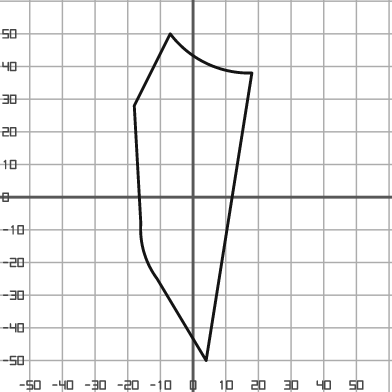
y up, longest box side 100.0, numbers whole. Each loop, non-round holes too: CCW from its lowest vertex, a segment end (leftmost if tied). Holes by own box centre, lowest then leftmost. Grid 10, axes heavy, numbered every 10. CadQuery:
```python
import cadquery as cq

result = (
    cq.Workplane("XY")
    .moveTo(4.0, -50.0)
    .lineTo(18.0, 38.0)
    .threePointArc((4.0, 41.0), (-7.0, 50.0))
    .lineTo(-18.0, 28.0)
    .lineTo(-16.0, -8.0)
    .threePointArc((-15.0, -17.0), (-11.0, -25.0))
    .close()
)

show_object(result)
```